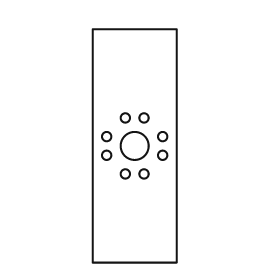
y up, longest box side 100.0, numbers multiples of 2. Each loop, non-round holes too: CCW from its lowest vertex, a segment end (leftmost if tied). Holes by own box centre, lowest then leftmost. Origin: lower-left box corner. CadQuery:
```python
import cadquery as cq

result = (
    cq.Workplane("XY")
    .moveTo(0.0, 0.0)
    .lineTo(36.0, 0.0)
    .lineTo(36.0, 100.0)
    .lineTo(0.0, 100.0)
    .close()
    .moveTo(14.0, 38.0)
    .circle(2.0)
    .moveTo(22.0, 38.0)
    .circle(2.0)
    .moveTo(6.0, 46.0)
    .circle(2.0)
    .moveTo(30.0, 46.0)
    .circle(2.0)
    .moveTo(18.0, 50.0)
    .circle(6.0)
    .moveTo(6.0, 54.0)
    .circle(2.0)
    .moveTo(30.0, 54.0)
    .circle(2.0)
    .moveTo(14.0, 62.0)
    .circle(2.0)
    .moveTo(22.0, 62.0)
    .circle(2.0)
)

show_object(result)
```